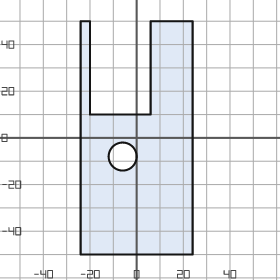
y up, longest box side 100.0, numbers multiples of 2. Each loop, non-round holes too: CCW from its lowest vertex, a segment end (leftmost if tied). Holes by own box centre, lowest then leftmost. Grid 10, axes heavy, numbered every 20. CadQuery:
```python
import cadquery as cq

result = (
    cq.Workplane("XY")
    .moveTo(-24.0, -50.0)
    .lineTo(24.0, -50.0)
    .lineTo(24.0, 50.0)
    .lineTo(6.0, 50.0)
    .lineTo(6.0, 10.0)
    .lineTo(-20.0, 10.0)
    .lineTo(-20.0, 50.0)
    .lineTo(-24.0, 50.0)
    .close()
    .moveTo(-6.0, -8.0)
    .circle(6.0)
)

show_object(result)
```